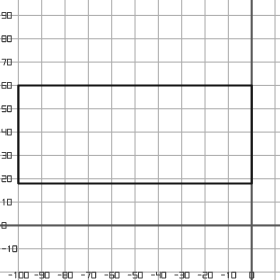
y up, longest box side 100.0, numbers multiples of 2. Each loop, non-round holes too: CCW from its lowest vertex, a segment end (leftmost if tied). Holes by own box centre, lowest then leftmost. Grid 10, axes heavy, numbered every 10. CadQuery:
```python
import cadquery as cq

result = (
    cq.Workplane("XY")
    .moveTo(-100.0, 18.0)
    .lineTo(0.0, 18.0)
    .lineTo(0.0, 60.0)
    .lineTo(-100.0, 60.0)
    .close()
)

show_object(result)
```